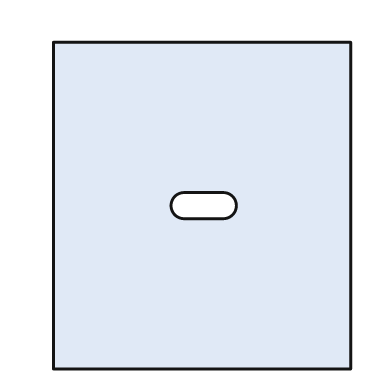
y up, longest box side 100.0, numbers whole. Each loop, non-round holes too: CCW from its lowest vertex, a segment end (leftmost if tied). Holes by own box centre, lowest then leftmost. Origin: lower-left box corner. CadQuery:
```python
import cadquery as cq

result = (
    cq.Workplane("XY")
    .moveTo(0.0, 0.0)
    .lineTo(91.0, 0.0)
    .lineTo(91.0, 100.0)
    .lineTo(0.0, 100.0)
    .close()
    .moveTo(40.0, 46.0)
    .lineTo(52.0, 46.0)
    .threePointArc((56.0, 50.0), (52.0, 54.0))
    .lineTo(40.0, 54.0)
    .threePointArc((36.0, 50.0), (40.0, 46.0))
    .close()
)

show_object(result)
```